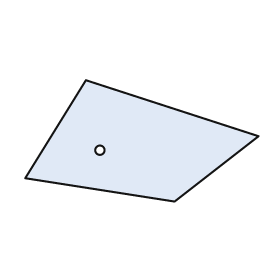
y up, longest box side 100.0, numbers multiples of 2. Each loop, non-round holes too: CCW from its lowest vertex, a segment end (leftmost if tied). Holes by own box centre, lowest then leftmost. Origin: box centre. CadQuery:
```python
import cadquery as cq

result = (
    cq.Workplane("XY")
    .moveTo(14.0, -26.0)
    .lineTo(50.0, 2.0)
    .lineTo(-24.0, 26.0)
    .lineTo(-50.0, -16.0)
    .close()
    .moveTo(-18.0, -4.0)
    .circle(2.0)
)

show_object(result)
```